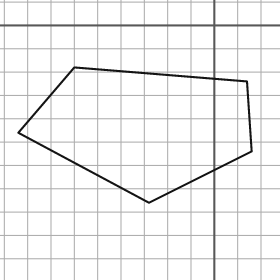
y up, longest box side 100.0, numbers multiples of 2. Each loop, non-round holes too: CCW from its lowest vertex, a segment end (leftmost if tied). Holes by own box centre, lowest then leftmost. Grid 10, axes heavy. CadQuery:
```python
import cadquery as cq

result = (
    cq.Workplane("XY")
    .moveTo(-28.0, -76.0)
    .lineTo(16.0, -54.0)
    .lineTo(14.0, -24.0)
    .lineTo(-60.0, -18.0)
    .lineTo(-84.0, -46.0)
    .close()
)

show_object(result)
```